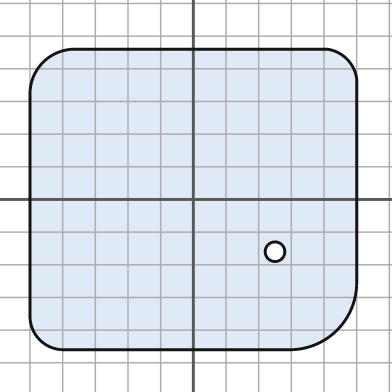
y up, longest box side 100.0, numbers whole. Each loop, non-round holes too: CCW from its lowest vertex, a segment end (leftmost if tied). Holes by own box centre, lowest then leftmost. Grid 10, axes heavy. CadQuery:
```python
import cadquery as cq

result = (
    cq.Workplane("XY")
    .moveTo(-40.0, -46.0)
    .lineTo(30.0, -46.0)
    .threePointArc((44.0, -40.0), (50.0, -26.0))
    .lineTo(50.0, 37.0)
    .threePointArc((47.0, 43.0), (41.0, 46.0))
    .lineTo(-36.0, 46.0)
    .threePointArc((-46.0, 42.0), (-50.0, 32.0))
    .lineTo(-50.0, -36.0)
    .threePointArc((-47.0, -43.0), (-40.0, -46.0))
    .close()
    .moveTo(25.0, -16.0)
    .circle(3.0)
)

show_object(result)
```